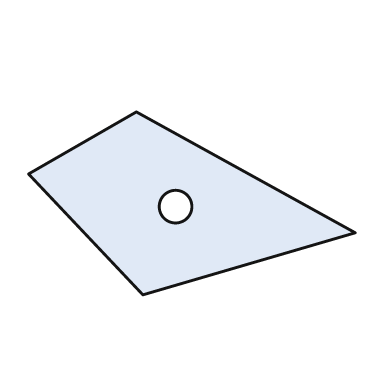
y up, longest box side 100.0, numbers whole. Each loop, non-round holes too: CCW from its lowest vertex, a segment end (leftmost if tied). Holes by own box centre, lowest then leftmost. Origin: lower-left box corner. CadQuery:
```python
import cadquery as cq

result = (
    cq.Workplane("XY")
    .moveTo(35.0, 0.0)
    .lineTo(100.0, 19.0)
    .lineTo(33.0, 56.0)
    .lineTo(0.0, 37.0)
    .close()
    .moveTo(45.0, 27.0)
    .circle(5.0)
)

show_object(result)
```